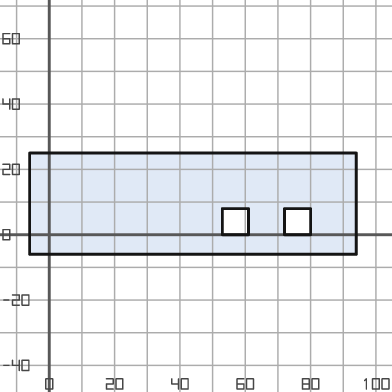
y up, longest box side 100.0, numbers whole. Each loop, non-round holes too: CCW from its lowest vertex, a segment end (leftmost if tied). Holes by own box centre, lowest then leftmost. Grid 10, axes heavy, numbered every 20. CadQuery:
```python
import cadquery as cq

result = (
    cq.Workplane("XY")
    .moveTo(-6.0, -6.0)
    .lineTo(94.0, -6.0)
    .lineTo(94.0, 25.0)
    .lineTo(-6.0, 25.0)
    .close()
    .moveTo(53.0, 0.0)
    .lineTo(61.0, 0.0)
    .lineTo(61.0, 8.0)
    .lineTo(53.0, 8.0)
    .close()
    .moveTo(72.0, 0.0)
    .lineTo(80.0, 0.0)
    .lineTo(80.0, 8.0)
    .lineTo(72.0, 8.0)
    .close()
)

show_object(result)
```